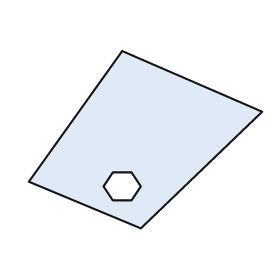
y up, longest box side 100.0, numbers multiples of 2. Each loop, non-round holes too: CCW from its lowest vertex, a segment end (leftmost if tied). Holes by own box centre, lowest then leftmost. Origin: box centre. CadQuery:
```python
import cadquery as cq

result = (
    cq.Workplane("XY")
    .moveTo(-2.0, -38.0)
    .lineTo(50.0, 12.0)
    .lineTo(-10.0, 38.0)
    .lineTo(-50.0, -18.0)
    .close()
    .moveTo(-14.0, -26.0)
    .lineTo(-6.0, -26.0)
    .lineTo(-2.0, -20.0)
    .lineTo(-6.0, -14.0)
    .lineTo(-14.0, -14.0)
    .lineTo(-18.0, -20.0)
    .close()
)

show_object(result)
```